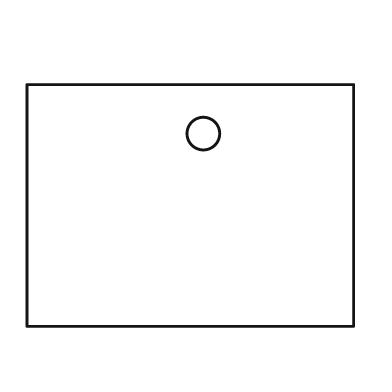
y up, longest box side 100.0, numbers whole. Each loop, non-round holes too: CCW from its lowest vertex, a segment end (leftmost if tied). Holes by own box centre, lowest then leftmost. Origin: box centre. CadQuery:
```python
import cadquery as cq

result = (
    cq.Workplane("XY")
    .moveTo(-50.0, -37.0)
    .lineTo(50.0, -37.0)
    .lineTo(50.0, 37.0)
    .lineTo(-50.0, 37.0)
    .close()
    .moveTo(4.0, 22.0)
    .circle(5.0)
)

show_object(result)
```